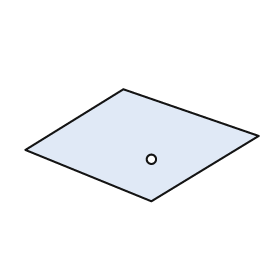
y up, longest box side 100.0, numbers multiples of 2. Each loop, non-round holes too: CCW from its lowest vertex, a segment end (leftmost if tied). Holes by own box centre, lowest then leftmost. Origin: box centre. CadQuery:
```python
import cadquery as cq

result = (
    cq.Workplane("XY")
    .moveTo(4.0, -24.0)
    .lineTo(50.0, 4.0)
    .lineTo(-8.0, 24.0)
    .lineTo(-50.0, -2.0)
    .close()
    .moveTo(4.0, -6.0)
    .circle(2.0)
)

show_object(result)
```